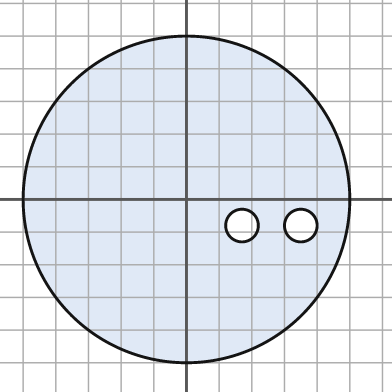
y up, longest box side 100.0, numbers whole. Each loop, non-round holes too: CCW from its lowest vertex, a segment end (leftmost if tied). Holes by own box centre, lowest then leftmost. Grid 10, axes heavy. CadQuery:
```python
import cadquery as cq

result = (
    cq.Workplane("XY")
    .moveTo(0.0, 0.0)
    .circle(50.0)
    .moveTo(17.0, -8.0)
    .circle(5.0)
    .moveTo(35.0, -8.0)
    .circle(5.0)
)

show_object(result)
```